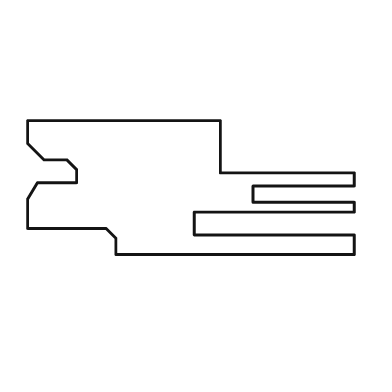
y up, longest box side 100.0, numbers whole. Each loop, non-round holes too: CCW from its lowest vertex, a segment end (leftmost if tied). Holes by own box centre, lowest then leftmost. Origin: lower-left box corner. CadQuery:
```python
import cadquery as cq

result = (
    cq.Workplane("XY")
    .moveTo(27.0, 0.0)
    .lineTo(100.0, 0.0)
    .lineTo(100.0, 6.0)
    .lineTo(51.0, 6.0)
    .lineTo(51.0, 13.0)
    .lineTo(100.0, 13.0)
    .lineTo(100.0, 16.0)
    .lineTo(69.0, 16.0)
    .lineTo(69.0, 21.0)
    .lineTo(100.0, 21.0)
    .lineTo(100.0, 25.0)
    .lineTo(59.0, 25.0)
    .lineTo(59.0, 41.0)
    .lineTo(0.0, 41.0)
    .lineTo(0.0, 34.0)
    .lineTo(5.0, 29.0)
    .lineTo(12.0, 29.0)
    .lineTo(15.0, 26.0)
    .lineTo(15.0, 22.0)
    .lineTo(3.0, 22.0)
    .lineTo(0.0, 17.0)
    .lineTo(0.0, 8.0)
    .lineTo(24.0, 8.0)
    .lineTo(27.0, 5.0)
    .close()
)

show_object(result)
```